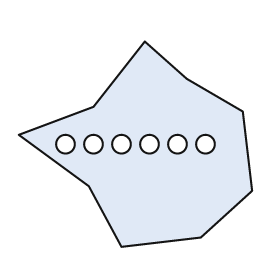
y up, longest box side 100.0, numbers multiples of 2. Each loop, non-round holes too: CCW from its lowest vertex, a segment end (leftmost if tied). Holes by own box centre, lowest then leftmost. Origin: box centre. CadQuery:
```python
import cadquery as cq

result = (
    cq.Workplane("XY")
    .moveTo(-6.0, -44.0)
    .lineTo(28.0, -40.0)
    .lineTo(50.0, -20.0)
    .lineTo(46.0, 14.0)
    .lineTo(22.0, 28.0)
    .lineTo(4.0, 44.0)
    .lineTo(-18.0, 16.0)
    .lineTo(-50.0, 4.0)
    .lineTo(-20.0, -18.0)
    .close()
    .moveTo(-30.0, 0.0)
    .circle(4.0)
    .moveTo(-18.0, 0.0)
    .circle(4.0)
    .moveTo(-6.0, 0.0)
    .circle(4.0)
    .moveTo(6.0, 0.0)
    .circle(4.0)
    .moveTo(18.0, 0.0)
    .circle(4.0)
    .moveTo(30.0, 0.0)
    .circle(4.0)
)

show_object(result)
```